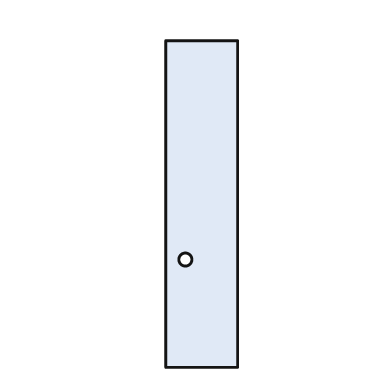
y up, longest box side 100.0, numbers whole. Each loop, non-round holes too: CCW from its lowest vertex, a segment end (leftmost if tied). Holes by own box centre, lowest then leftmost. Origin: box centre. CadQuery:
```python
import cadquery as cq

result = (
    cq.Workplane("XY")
    .moveTo(-11.0, -50.0)
    .lineTo(11.0, -50.0)
    .lineTo(11.0, 50.0)
    .lineTo(-11.0, 50.0)
    .close()
    .moveTo(-5.0, -17.0)
    .circle(2.0)
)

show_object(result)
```